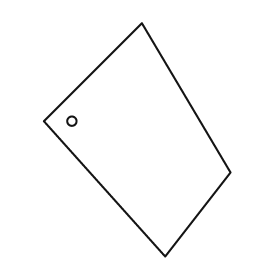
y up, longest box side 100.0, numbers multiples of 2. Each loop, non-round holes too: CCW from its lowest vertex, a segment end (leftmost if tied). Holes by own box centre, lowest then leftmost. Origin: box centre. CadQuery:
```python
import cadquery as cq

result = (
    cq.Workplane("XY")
    .moveTo(12.0, -50.0)
    .lineTo(40.0, -14.0)
    .lineTo(2.0, 50.0)
    .lineTo(-40.0, 8.0)
    .close()
    .moveTo(-28.0, 8.0)
    .circle(2.0)
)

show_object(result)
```